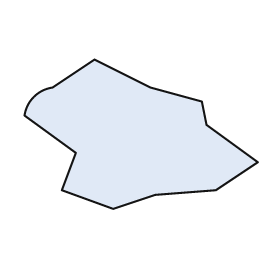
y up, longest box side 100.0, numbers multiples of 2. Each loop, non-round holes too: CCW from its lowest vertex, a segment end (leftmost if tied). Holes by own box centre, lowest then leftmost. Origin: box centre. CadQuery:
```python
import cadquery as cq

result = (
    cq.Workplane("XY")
    .moveTo(-12.0, -32.0)
    .lineTo(6.0, -26.0)
    .lineTo(32.0, -24.0)
    .lineTo(50.0, -12.0)
    .lineTo(28.0, 4.0)
    .lineTo(26.0, 14.0)
    .lineTo(4.0, 20.0)
    .lineTo(-20.0, 32.0)
    .lineTo(-38.0, 20.0)
    .threePointArc((-46.0, 16.0), (-50.0, 8.0))
    .lineTo(-28.0, -8.0)
    .lineTo(-34.0, -24.0)
    .close()
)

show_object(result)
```